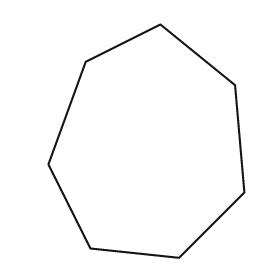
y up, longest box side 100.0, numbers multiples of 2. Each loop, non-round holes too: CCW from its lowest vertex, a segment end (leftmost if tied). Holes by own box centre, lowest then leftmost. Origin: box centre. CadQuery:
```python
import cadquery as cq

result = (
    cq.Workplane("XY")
    .moveTo(14.0, -50.0)
    .lineTo(42.0, -22.0)
    .lineTo(38.0, 24.0)
    .lineTo(6.0, 50.0)
    .lineTo(-26.0, 34.0)
    .lineTo(-42.0, -10.0)
    .lineTo(-24.0, -46.0)
    .close()
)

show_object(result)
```